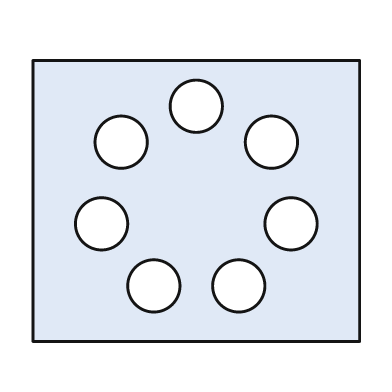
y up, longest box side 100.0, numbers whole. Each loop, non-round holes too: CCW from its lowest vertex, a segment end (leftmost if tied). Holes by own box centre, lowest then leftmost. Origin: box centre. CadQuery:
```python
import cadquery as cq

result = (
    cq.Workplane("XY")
    .moveTo(-50.0, -43.0)
    .lineTo(50.0, -43.0)
    .lineTo(50.0, 43.0)
    .lineTo(-50.0, 43.0)
    .close()
    .moveTo(-13.0, -26.0)
    .circle(8.0)
    .moveTo(13.0, -26.0)
    .circle(8.0)
    .moveTo(-29.0, -7.0)
    .circle(8.0)
    .moveTo(29.0, -7.0)
    .circle(8.0)
    .moveTo(-23.0, 18.0)
    .circle(8.0)
    .moveTo(23.0, 18.0)
    .circle(8.0)
    .moveTo(0.0, 29.0)
    .circle(8.0)
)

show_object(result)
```